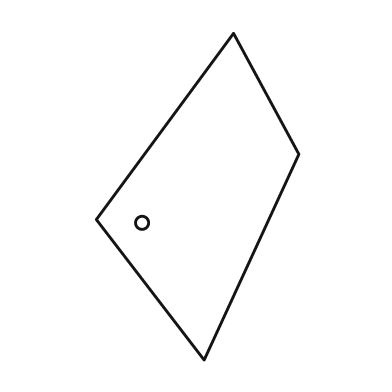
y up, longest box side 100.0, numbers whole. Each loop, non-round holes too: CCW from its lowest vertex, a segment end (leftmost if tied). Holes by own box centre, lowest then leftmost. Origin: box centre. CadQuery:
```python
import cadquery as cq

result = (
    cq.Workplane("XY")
    .moveTo(2.0, -50.0)
    .lineTo(31.0, 13.0)
    .lineTo(11.0, 50.0)
    .lineTo(-31.0, -7.0)
    .close()
    .moveTo(-17.0, -8.0)
    .circle(2.0)
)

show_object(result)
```